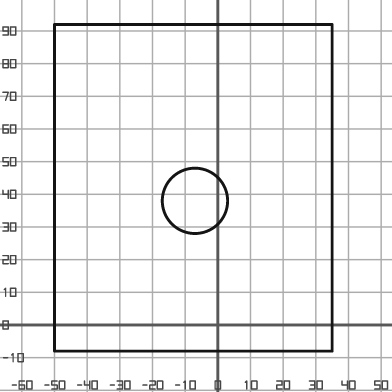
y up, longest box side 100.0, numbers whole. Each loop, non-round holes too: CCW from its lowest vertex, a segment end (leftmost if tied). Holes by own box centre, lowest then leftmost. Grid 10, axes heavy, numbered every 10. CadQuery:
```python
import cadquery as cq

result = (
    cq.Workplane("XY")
    .moveTo(-50.0, -8.0)
    .lineTo(35.0, -8.0)
    .lineTo(35.0, 92.0)
    .lineTo(-50.0, 92.0)
    .close()
    .moveTo(-7.0, 38.0)
    .circle(10.0)
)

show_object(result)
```